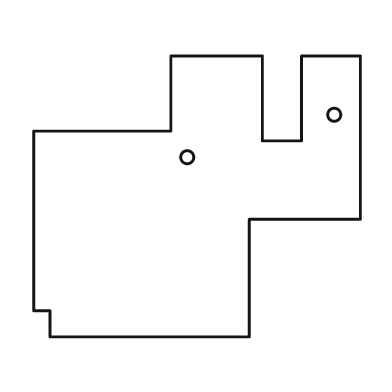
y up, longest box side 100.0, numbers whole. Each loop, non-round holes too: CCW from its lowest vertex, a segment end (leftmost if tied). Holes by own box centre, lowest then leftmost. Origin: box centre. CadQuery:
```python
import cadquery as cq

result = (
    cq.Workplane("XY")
    .moveTo(-45.0, -43.0)
    .lineTo(16.0, -43.0)
    .lineTo(16.0, -7.0)
    .lineTo(50.0, -7.0)
    .lineTo(50.0, 43.0)
    .lineTo(32.0, 43.0)
    .lineTo(32.0, 17.0)
    .lineTo(20.0, 17.0)
    .lineTo(20.0, 43.0)
    .lineTo(-8.0, 43.0)
    .lineTo(-8.0, 20.0)
    .lineTo(-50.0, 20.0)
    .lineTo(-50.0, -35.0)
    .lineTo(-45.0, -35.0)
    .close()
    .moveTo(-3.0, 12.0)
    .circle(2.0)
    .moveTo(42.0, 25.0)
    .circle(2.0)
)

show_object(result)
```